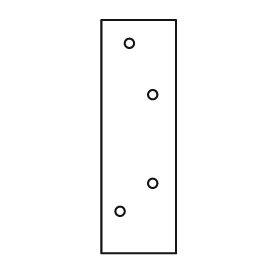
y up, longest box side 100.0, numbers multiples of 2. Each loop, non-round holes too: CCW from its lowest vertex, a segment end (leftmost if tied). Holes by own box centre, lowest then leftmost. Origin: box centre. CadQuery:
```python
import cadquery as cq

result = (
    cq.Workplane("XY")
    .moveTo(-16.0, -50.0)
    .lineTo(16.0, -50.0)
    .lineTo(16.0, 50.0)
    .lineTo(-16.0, 50.0)
    .close()
    .moveTo(-8.0, -32.0)
    .circle(2.0)
    .moveTo(6.0, -20.0)
    .circle(2.0)
    .moveTo(6.0, 18.0)
    .circle(2.0)
    .moveTo(-4.0, 40.0)
    .circle(2.0)
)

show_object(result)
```